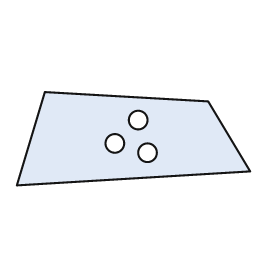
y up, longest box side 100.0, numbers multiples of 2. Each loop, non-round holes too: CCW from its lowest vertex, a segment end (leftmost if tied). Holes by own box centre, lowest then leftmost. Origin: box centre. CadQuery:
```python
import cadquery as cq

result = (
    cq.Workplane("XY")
    .moveTo(-50.0, -20.0)
    .lineTo(50.0, -14.0)
    .lineTo(32.0, 16.0)
    .lineTo(-38.0, 20.0)
    .close()
    .moveTo(6.0, -6.0)
    .circle(4.0)
    .moveTo(-8.0, -2.0)
    .circle(4.0)
    .moveTo(2.0, 8.0)
    .circle(4.0)
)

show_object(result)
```